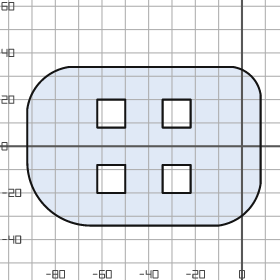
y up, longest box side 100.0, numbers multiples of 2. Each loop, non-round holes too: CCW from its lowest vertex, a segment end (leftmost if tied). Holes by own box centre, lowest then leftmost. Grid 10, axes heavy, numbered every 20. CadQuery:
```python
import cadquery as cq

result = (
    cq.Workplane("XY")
    .moveTo(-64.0, -34.0)
    .lineTo(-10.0, -34.0)
    .threePointArc((2.0, -28.0), (8.0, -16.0))
    .lineTo(8.0, 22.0)
    .threePointArc((4.0, 30.0), (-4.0, 34.0))
    .lineTo(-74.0, 34.0)
    .threePointArc((-86.0, 28.0), (-92.0, 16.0))
    .lineTo(-92.0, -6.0)
    .threePointArc((-84.0, -26.0), (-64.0, -34.0))
    .close()
    .moveTo(-62.0, -20.0)
    .lineTo(-50.0, -20.0)
    .lineTo(-50.0, -8.0)
    .lineTo(-62.0, -8.0)
    .close()
    .moveTo(-34.0, -20.0)
    .lineTo(-22.0, -20.0)
    .lineTo(-22.0, -8.0)
    .lineTo(-34.0, -8.0)
    .close()
    .moveTo(-62.0, 8.0)
    .lineTo(-50.0, 8.0)
    .lineTo(-50.0, 20.0)
    .lineTo(-62.0, 20.0)
    .close()
    .moveTo(-34.0, 8.0)
    .lineTo(-22.0, 8.0)
    .lineTo(-22.0, 20.0)
    .lineTo(-34.0, 20.0)
    .close()
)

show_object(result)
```